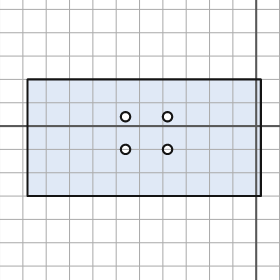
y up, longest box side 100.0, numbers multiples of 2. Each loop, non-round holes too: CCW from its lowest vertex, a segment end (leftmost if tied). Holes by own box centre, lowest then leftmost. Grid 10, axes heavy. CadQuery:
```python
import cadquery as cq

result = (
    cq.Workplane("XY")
    .moveTo(-98.0, -30.0)
    .lineTo(2.0, -30.0)
    .lineTo(2.0, 20.0)
    .lineTo(-98.0, 20.0)
    .close()
    .moveTo(-56.0, -10.0)
    .circle(2.0)
    .moveTo(-38.0, -10.0)
    .circle(2.0)
    .moveTo(-56.0, 4.0)
    .circle(2.0)
    .moveTo(-38.0, 4.0)
    .circle(2.0)
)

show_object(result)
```